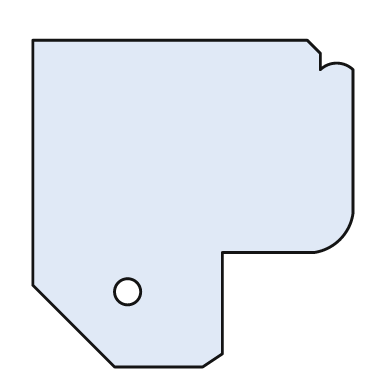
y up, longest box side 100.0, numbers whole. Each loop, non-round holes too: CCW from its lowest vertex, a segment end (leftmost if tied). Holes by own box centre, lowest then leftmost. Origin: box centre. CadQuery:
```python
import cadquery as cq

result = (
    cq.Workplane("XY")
    .moveTo(-24.0, -50.0)
    .lineTo(3.0, -50.0)
    .lineTo(9.0, -46.0)
    .lineTo(9.0, -15.0)
    .lineTo(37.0, -15.0)
    .threePointArc((45.0, -11.0), (49.0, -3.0))
    .lineTo(49.0, 41.0)
    .threePointArc((44.0, 43.0), (39.0, 41.0))
    .lineTo(39.0, 46.0)
    .lineTo(35.0, 50.0)
    .lineTo(-49.0, 50.0)
    .lineTo(-49.0, -25.0)
    .close()
    .moveTo(-20.0, -27.0)
    .circle(4.0)
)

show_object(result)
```